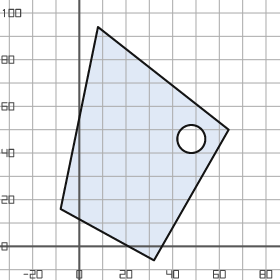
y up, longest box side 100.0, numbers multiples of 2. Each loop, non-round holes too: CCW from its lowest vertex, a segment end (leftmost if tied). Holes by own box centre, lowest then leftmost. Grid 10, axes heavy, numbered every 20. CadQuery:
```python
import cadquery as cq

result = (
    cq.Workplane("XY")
    .moveTo(32.0, -6.0)
    .lineTo(64.0, 50.0)
    .lineTo(8.0, 94.0)
    .lineTo(-8.0, 16.0)
    .close()
    .moveTo(48.0, 46.0)
    .circle(6.0)
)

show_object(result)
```